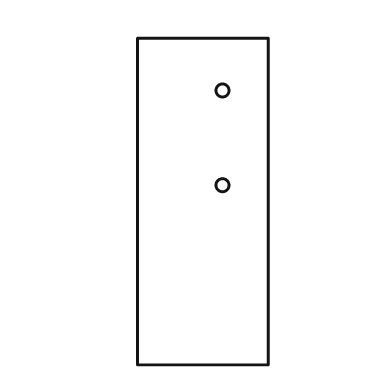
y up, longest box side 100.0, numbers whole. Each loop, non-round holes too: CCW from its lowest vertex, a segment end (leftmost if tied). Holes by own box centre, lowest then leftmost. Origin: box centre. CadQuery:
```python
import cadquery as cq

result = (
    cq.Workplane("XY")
    .moveTo(-20.0, -50.0)
    .lineTo(20.0, -50.0)
    .lineTo(20.0, 50.0)
    .lineTo(-20.0, 50.0)
    .close()
    .moveTo(6.0, 5.0)
    .circle(2.0)
    .moveTo(6.0, 34.0)
    .circle(2.0)
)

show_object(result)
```